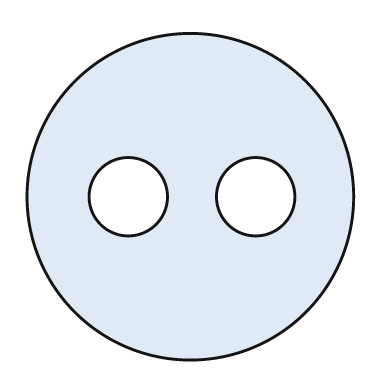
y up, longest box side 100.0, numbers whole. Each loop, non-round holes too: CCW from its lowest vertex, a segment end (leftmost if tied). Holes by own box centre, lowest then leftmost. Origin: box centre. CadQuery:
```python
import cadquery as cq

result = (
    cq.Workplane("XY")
    .moveTo(0.0, 0.0)
    .circle(50.0)
    .moveTo(-19.0, 0.0)
    .circle(12.0)
    .moveTo(20.0, 0.0)
    .circle(12.0)
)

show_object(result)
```